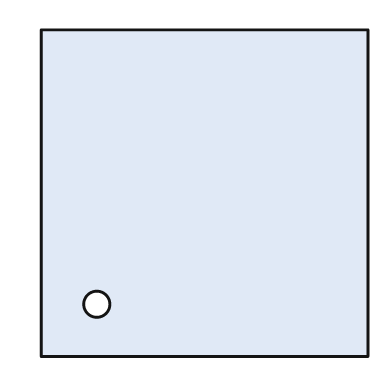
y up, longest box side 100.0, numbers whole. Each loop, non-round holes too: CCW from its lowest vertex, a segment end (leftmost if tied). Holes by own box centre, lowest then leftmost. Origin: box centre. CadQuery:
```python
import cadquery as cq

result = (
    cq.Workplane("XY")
    .moveTo(-50.0, -50.0)
    .lineTo(50.0, -50.0)
    .lineTo(50.0, 50.0)
    .lineTo(-50.0, 50.0)
    .close()
    .moveTo(-33.0, -34.0)
    .circle(4.0)
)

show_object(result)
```